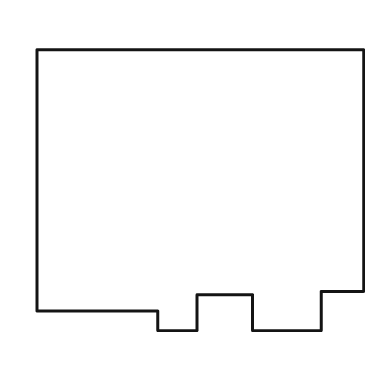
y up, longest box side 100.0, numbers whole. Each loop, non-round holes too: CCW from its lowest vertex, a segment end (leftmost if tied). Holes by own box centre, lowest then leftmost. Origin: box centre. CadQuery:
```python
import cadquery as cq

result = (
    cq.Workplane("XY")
    .moveTo(-13.0, -43.0)
    .lineTo(-1.0, -43.0)
    .lineTo(-1.0, -32.0)
    .lineTo(16.0, -32.0)
    .lineTo(16.0, -43.0)
    .lineTo(37.0, -43.0)
    .lineTo(37.0, -31.0)
    .lineTo(50.0, -31.0)
    .lineTo(50.0, 43.0)
    .lineTo(-50.0, 43.0)
    .lineTo(-50.0, -37.0)
    .lineTo(-13.0, -37.0)
    .close()
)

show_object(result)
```